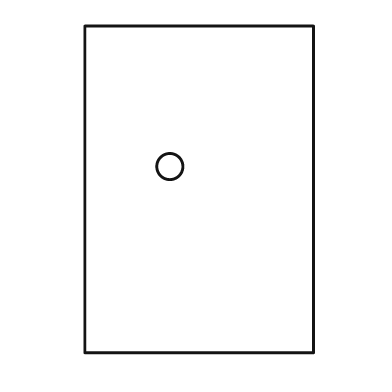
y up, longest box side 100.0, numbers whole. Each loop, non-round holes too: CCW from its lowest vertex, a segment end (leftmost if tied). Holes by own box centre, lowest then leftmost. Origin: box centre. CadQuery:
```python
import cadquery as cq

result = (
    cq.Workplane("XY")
    .moveTo(-35.0, -50.0)
    .lineTo(35.0, -50.0)
    .lineTo(35.0, 50.0)
    .lineTo(-35.0, 50.0)
    .close()
    .moveTo(-9.0, 7.0)
    .circle(4.0)
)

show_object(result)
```